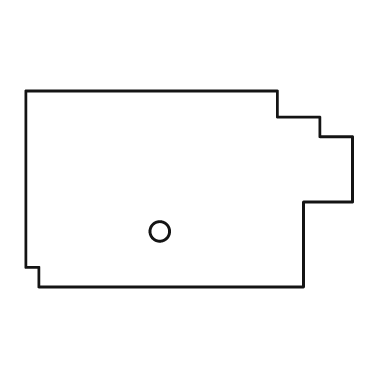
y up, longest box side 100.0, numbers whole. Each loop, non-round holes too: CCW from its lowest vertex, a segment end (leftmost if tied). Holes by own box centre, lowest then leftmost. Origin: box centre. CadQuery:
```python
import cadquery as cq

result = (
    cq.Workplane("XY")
    .moveTo(-46.0, -30.0)
    .lineTo(35.0, -30.0)
    .lineTo(35.0, -4.0)
    .lineTo(50.0, -4.0)
    .lineTo(50.0, 16.0)
    .lineTo(40.0, 16.0)
    .lineTo(40.0, 22.0)
    .lineTo(27.0, 22.0)
    .lineTo(27.0, 30.0)
    .lineTo(-50.0, 30.0)
    .lineTo(-50.0, -24.0)
    .lineTo(-46.0, -24.0)
    .close()
    .moveTo(-9.0, -13.0)
    .circle(3.0)
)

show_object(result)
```